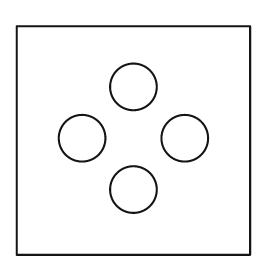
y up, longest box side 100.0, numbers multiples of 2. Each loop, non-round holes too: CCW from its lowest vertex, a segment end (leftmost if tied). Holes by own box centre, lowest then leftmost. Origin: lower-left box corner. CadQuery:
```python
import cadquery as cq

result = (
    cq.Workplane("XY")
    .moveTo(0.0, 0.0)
    .lineTo(100.0, 0.0)
    .lineTo(100.0, 98.0)
    .lineTo(0.0, 98.0)
    .close()
    .moveTo(50.0, 28.0)
    .circle(10.0)
    .moveTo(28.0, 50.0)
    .circle(10.0)
    .moveTo(72.0, 50.0)
    .circle(10.0)
    .moveTo(50.0, 72.0)
    .circle(10.0)
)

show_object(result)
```